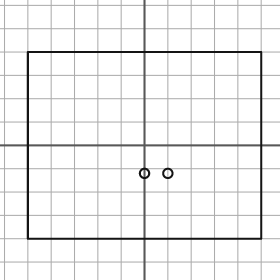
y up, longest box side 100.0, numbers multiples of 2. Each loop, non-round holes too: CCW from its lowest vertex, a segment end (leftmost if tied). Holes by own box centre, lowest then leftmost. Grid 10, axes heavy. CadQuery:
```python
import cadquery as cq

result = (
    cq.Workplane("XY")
    .moveTo(-50.0, -40.0)
    .lineTo(50.0, -40.0)
    .lineTo(50.0, 40.0)
    .lineTo(-50.0, 40.0)
    .close()
    .moveTo(0.0, -12.0)
    .circle(2.0)
    .moveTo(10.0, -12.0)
    .circle(2.0)
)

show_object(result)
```